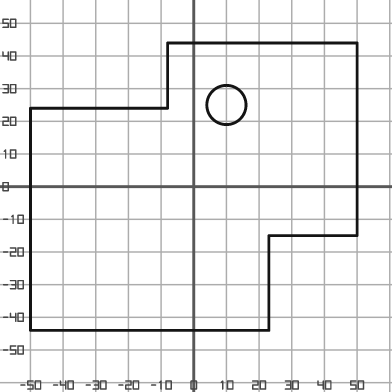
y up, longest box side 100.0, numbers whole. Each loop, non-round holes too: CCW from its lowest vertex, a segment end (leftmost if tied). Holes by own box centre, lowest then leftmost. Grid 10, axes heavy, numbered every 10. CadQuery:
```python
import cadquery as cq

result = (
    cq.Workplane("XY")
    .moveTo(-50.0, -44.0)
    .lineTo(23.0, -44.0)
    .lineTo(23.0, -15.0)
    .lineTo(50.0, -15.0)
    .lineTo(50.0, 44.0)
    .lineTo(-8.0, 44.0)
    .lineTo(-8.0, 24.0)
    .lineTo(-50.0, 24.0)
    .close()
    .moveTo(10.0, 25.0)
    .circle(6.0)
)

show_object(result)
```